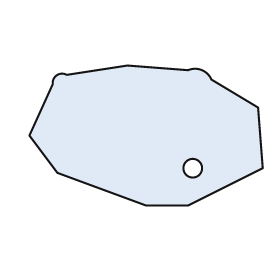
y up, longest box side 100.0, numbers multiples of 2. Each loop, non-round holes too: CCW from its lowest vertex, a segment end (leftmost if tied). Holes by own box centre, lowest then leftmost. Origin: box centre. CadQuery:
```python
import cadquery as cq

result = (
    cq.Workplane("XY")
    .moveTo(0.0, -30.0)
    .lineTo(18.0, -30.0)
    .lineTo(50.0, -14.0)
    .lineTo(48.0, 12.0)
    .lineTo(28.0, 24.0)
    .threePointArc((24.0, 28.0), (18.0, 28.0))
    .lineTo(-8.0, 30.0)
    .lineTo(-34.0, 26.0)
    .threePointArc((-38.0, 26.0), (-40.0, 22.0))
    .lineTo(-50.0, 0.0)
    .lineTo(-38.0, -16.0)
    .close()
    .moveTo(20.0, -14.0)
    .circle(4.0)
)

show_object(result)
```